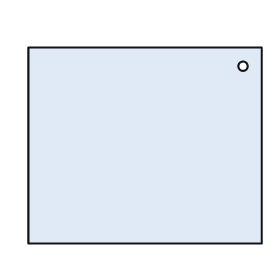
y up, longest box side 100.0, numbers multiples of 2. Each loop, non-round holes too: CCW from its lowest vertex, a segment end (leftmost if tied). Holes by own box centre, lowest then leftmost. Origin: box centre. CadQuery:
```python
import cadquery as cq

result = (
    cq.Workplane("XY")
    .moveTo(-50.0, -42.0)
    .lineTo(50.0, -42.0)
    .lineTo(50.0, 42.0)
    .lineTo(-50.0, 42.0)
    .close()
    .moveTo(42.0, 34.0)
    .circle(2.0)
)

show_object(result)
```